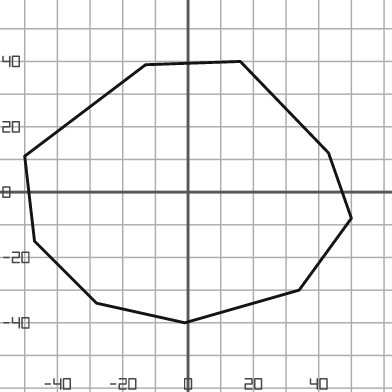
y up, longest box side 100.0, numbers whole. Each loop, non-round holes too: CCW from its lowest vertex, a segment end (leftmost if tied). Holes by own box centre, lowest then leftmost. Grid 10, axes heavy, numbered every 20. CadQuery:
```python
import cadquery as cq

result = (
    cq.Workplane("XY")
    .moveTo(-1.0, -40.0)
    .lineTo(34.0, -30.0)
    .lineTo(50.0, -8.0)
    .lineTo(43.0, 12.0)
    .lineTo(16.0, 40.0)
    .lineTo(-13.0, 39.0)
    .lineTo(-50.0, 11.0)
    .lineTo(-47.0, -15.0)
    .lineTo(-28.0, -34.0)
    .close()
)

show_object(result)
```